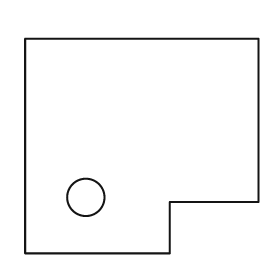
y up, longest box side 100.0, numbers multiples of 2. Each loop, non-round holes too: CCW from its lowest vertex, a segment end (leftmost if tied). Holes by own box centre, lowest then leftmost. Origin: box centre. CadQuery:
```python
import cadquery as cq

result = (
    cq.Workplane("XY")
    .moveTo(-50.0, -46.0)
    .lineTo(12.0, -46.0)
    .lineTo(12.0, -24.0)
    .lineTo(50.0, -24.0)
    .lineTo(50.0, 46.0)
    .lineTo(-50.0, 46.0)
    .close()
    .moveTo(-24.0, -22.0)
    .circle(8.0)
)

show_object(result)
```